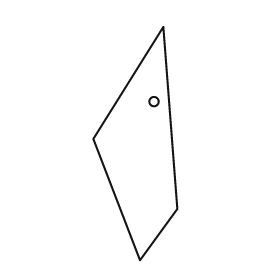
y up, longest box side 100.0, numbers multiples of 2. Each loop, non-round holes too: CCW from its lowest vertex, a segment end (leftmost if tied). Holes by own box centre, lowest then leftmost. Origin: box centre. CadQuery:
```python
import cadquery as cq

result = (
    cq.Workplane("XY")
    .moveTo(2.0, -50.0)
    .lineTo(18.0, -28.0)
    .lineTo(12.0, 50.0)
    .lineTo(-18.0, 2.0)
    .close()
    .moveTo(8.0, 18.0)
    .circle(2.0)
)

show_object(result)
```